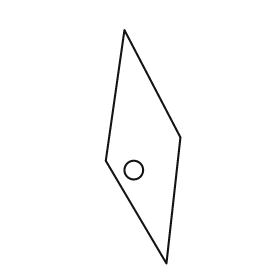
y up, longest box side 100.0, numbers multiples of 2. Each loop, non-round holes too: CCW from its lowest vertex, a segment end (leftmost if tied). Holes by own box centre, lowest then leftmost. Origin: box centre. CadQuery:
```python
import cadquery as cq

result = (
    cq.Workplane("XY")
    .moveTo(10.0, -50.0)
    .lineTo(16.0, 4.0)
    .lineTo(-8.0, 50.0)
    .lineTo(-16.0, -6.0)
    .close()
    .moveTo(-4.0, -10.0)
    .circle(4.0)
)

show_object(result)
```